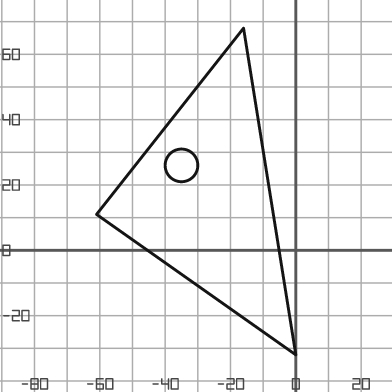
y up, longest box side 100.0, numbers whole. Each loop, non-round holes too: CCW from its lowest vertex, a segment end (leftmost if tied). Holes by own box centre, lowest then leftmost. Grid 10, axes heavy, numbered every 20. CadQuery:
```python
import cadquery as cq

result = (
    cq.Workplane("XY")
    .moveTo(0.0, -32.0)
    .lineTo(-16.0, 68.0)
    .lineTo(-61.0, 11.0)
    .close()
    .moveTo(-35.0, 26.0)
    .circle(5.0)
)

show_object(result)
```